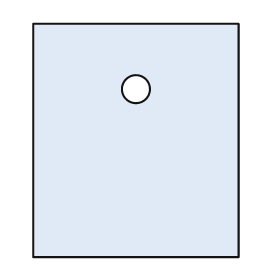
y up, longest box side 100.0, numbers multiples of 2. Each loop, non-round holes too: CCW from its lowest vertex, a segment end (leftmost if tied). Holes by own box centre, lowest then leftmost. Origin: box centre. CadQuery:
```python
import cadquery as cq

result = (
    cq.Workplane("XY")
    .moveTo(-44.0, -50.0)
    .lineTo(44.0, -50.0)
    .lineTo(44.0, 50.0)
    .lineTo(-44.0, 50.0)
    .close()
    .moveTo(0.0, 22.0)
    .circle(6.0)
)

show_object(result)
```